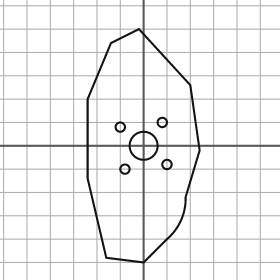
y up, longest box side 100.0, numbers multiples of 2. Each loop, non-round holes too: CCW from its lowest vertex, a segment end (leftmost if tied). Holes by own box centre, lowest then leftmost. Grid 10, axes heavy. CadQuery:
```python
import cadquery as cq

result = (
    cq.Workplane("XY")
    .moveTo(0.0, -50.0)
    .lineTo(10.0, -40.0)
    .threePointArc((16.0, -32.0), (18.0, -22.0))
    .lineTo(24.0, -2.0)
    .lineTo(20.0, 26.0)
    .lineTo(-2.0, 50.0)
    .lineTo(-14.0, 44.0)
    .lineTo(-24.0, 20.0)
    .lineTo(-24.0, -14.0)
    .lineTo(-16.0, -48.0)
    .close()
    .moveTo(-8.0, -10.0)
    .circle(2.0)
    .moveTo(10.0, -8.0)
    .circle(2.0)
    .moveTo(0.0, 0.0)
    .circle(6.0)
    .moveTo(-10.0, 8.0)
    .circle(2.0)
    .moveTo(8.0, 10.0)
    .circle(2.0)
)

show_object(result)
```